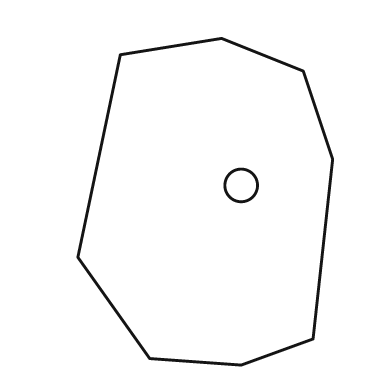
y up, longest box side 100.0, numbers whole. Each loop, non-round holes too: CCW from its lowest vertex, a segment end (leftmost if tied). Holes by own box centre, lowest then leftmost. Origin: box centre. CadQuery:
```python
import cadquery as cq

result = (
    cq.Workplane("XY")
    .moveTo(11.0, -50.0)
    .lineTo(33.0, -42.0)
    .lineTo(39.0, 13.0)
    .lineTo(30.0, 40.0)
    .lineTo(5.0, 50.0)
    .lineTo(-26.0, 45.0)
    .lineTo(-39.0, -17.0)
    .lineTo(-17.0, -48.0)
    .close()
    .moveTo(11.0, 5.0)
    .circle(5.0)
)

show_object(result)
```